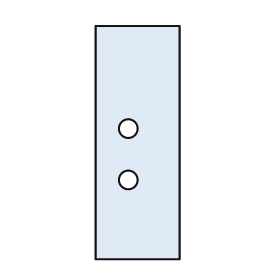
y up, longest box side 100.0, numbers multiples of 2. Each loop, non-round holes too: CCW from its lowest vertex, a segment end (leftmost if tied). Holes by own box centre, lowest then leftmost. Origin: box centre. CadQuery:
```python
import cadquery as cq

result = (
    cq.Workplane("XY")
    .moveTo(-18.0, -50.0)
    .lineTo(18.0, -50.0)
    .lineTo(18.0, 50.0)
    .lineTo(-18.0, 50.0)
    .close()
    .moveTo(-4.0, -16.0)
    .circle(4.0)
    .moveTo(-4.0, 6.0)
    .circle(4.0)
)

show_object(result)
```